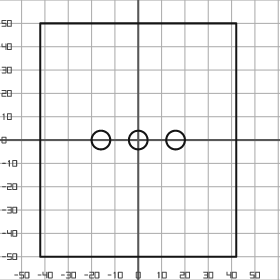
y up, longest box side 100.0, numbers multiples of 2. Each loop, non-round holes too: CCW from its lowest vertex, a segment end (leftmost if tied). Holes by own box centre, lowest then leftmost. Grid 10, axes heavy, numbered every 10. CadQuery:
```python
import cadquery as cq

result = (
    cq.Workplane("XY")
    .moveTo(-42.0, -50.0)
    .lineTo(42.0, -50.0)
    .lineTo(42.0, 50.0)
    .lineTo(-42.0, 50.0)
    .close()
    .moveTo(-16.0, 0.0)
    .circle(4.0)
    .moveTo(0.0, 0.0)
    .circle(4.0)
    .moveTo(16.0, 0.0)
    .circle(4.0)
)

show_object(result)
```